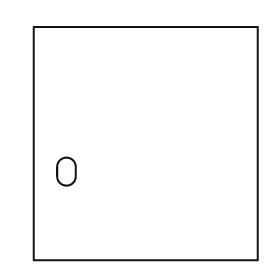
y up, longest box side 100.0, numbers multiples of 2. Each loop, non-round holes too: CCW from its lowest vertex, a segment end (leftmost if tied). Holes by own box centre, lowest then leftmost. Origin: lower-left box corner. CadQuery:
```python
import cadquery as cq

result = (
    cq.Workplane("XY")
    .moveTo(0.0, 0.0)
    .lineTo(96.0, 0.0)
    .lineTo(96.0, 100.0)
    .lineTo(0.0, 100.0)
    .close()
    .moveTo(10.0, 36.0)
    .threePointArc((14.0, 32.0), (18.0, 36.0))
    .lineTo(18.0, 40.0)
    .threePointArc((14.0, 44.0), (10.0, 40.0))
    .close()
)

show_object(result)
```